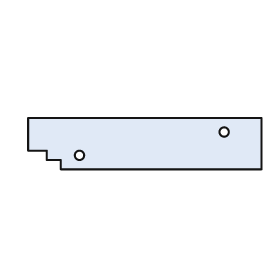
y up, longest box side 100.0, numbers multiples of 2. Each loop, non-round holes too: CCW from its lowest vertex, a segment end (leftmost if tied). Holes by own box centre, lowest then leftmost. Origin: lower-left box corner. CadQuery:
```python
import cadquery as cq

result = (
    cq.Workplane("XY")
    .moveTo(14.0, 0.0)
    .lineTo(100.0, 0.0)
    .lineTo(100.0, 22.0)
    .lineTo(0.0, 22.0)
    .lineTo(0.0, 8.0)
    .lineTo(8.0, 8.0)
    .lineTo(8.0, 4.0)
    .lineTo(14.0, 4.0)
    .close()
    .moveTo(22.0, 6.0)
    .circle(2.0)
    .moveTo(84.0, 16.0)
    .circle(2.0)
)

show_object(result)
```